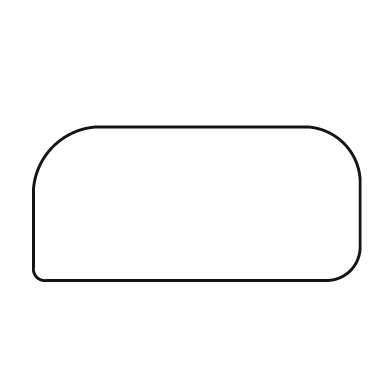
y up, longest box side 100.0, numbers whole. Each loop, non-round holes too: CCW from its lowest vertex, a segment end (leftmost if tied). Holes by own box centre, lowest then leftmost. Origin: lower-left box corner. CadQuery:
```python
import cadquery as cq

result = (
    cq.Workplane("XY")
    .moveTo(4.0, 0.0)
    .lineTo(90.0, 0.0)
    .threePointArc((97.0, 3.0), (100.0, 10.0))
    .lineTo(100.0, 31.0)
    .threePointArc((95.0, 42.0), (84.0, 47.0))
    .lineTo(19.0, 47.0)
    .threePointArc((6.0, 41.0), (0.0, 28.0))
    .lineTo(0.0, 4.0)
    .threePointArc((1.0, 1.0), (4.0, 0.0))
    .close()
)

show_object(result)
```